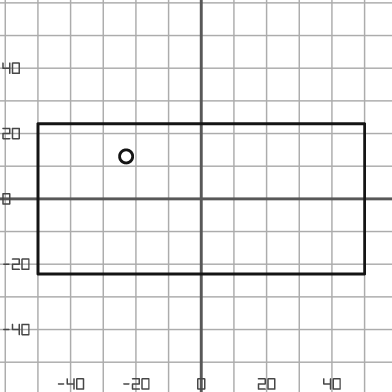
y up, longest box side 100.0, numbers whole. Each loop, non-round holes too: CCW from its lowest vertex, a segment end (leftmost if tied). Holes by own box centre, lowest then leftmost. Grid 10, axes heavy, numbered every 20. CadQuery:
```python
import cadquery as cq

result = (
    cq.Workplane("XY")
    .moveTo(-50.0, -23.0)
    .lineTo(50.0, -23.0)
    .lineTo(50.0, 23.0)
    .lineTo(-50.0, 23.0)
    .close()
    .moveTo(-23.0, 13.0)
    .circle(2.0)
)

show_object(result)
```